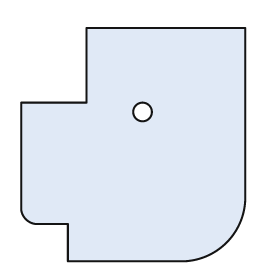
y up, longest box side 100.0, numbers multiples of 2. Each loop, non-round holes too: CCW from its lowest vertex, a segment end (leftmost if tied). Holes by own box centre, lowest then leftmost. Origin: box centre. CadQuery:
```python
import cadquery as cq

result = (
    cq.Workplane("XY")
    .moveTo(-28.0, -50.0)
    .lineTo(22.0, -50.0)
    .threePointArc((40.0, -42.0), (48.0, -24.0))
    .lineTo(48.0, 50.0)
    .lineTo(-20.0, 50.0)
    .lineTo(-20.0, 18.0)
    .lineTo(-48.0, 18.0)
    .lineTo(-48.0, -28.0)
    .threePointArc((-46.0, -32.0), (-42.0, -34.0))
    .lineTo(-28.0, -34.0)
    .close()
    .moveTo(4.0, 14.0)
    .circle(4.0)
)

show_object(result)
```